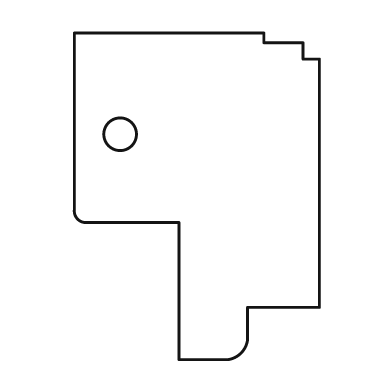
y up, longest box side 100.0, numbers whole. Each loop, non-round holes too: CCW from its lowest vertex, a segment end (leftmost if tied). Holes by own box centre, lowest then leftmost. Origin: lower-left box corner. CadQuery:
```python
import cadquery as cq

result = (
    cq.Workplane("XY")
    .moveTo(32.0, 0.0)
    .lineTo(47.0, 0.0)
    .threePointArc((51.0, 2.0), (53.0, 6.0))
    .lineTo(53.0, 16.0)
    .lineTo(75.0, 16.0)
    .lineTo(75.0, 92.0)
    .lineTo(70.0, 92.0)
    .lineTo(70.0, 97.0)
    .lineTo(58.0, 97.0)
    .lineTo(58.0, 100.0)
    .lineTo(0.0, 100.0)
    .lineTo(0.0, 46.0)
    .threePointArc((1.0, 43.0), (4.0, 42.0))
    .lineTo(32.0, 42.0)
    .close()
    .moveTo(14.0, 69.0)
    .circle(5.0)
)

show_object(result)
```